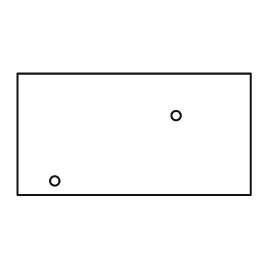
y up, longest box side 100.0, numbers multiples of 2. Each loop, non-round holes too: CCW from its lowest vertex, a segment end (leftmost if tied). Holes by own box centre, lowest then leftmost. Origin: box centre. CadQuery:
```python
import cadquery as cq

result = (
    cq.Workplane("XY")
    .moveTo(-50.0, -26.0)
    .lineTo(50.0, -26.0)
    .lineTo(50.0, 26.0)
    .lineTo(-50.0, 26.0)
    .close()
    .moveTo(-34.0, -20.0)
    .circle(2.0)
    .moveTo(18.0, 8.0)
    .circle(2.0)
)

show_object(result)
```